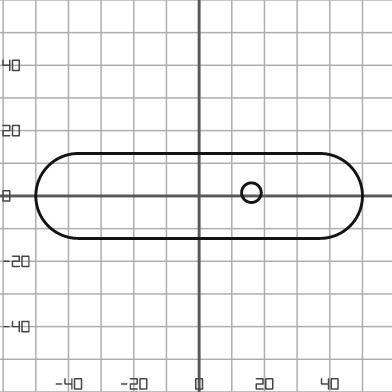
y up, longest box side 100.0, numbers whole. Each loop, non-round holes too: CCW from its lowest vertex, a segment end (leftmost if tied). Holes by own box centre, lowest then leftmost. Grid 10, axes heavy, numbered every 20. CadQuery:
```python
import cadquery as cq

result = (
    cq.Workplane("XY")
    .moveTo(-37.0, -13.0)
    .lineTo(37.0, -13.0)
    .threePointArc((50.0, 0.0), (37.0, 13.0))
    .lineTo(-37.0, 13.0)
    .threePointArc((-50.0, 0.0), (-37.0, -13.0))
    .close()
    .moveTo(16.0, 1.0)
    .circle(3.0)
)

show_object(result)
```